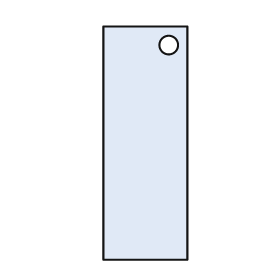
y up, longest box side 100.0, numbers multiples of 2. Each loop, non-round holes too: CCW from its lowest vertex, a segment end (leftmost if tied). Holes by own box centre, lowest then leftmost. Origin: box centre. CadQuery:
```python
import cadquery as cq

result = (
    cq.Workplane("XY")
    .moveTo(-18.0, -50.0)
    .lineTo(18.0, -50.0)
    .lineTo(18.0, 50.0)
    .lineTo(-18.0, 50.0)
    .close()
    .moveTo(10.0, 42.0)
    .circle(4.0)
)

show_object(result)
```